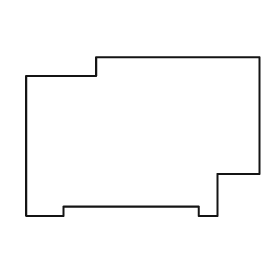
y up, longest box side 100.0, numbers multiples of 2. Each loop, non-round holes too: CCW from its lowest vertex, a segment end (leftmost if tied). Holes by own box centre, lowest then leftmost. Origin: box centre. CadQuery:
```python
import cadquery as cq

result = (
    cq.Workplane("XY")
    .moveTo(-50.0, -34.0)
    .lineTo(-34.0, -34.0)
    .lineTo(-34.0, -30.0)
    .lineTo(24.0, -30.0)
    .lineTo(24.0, -34.0)
    .lineTo(32.0, -34.0)
    .lineTo(32.0, -16.0)
    .lineTo(50.0, -16.0)
    .lineTo(50.0, 34.0)
    .lineTo(-20.0, 34.0)
    .lineTo(-20.0, 26.0)
    .lineTo(-50.0, 26.0)
    .close()
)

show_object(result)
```